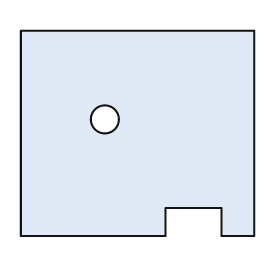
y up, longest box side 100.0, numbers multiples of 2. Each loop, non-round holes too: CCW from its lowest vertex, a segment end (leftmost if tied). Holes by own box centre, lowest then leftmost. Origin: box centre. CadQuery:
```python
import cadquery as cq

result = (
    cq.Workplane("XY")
    .moveTo(-50.0, -44.0)
    .lineTo(12.0, -44.0)
    .lineTo(12.0, -32.0)
    .lineTo(36.0, -32.0)
    .lineTo(36.0, -44.0)
    .lineTo(50.0, -44.0)
    .lineTo(50.0, 44.0)
    .lineTo(-50.0, 44.0)
    .close()
    .moveTo(-14.0, 6.0)
    .circle(6.0)
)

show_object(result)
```